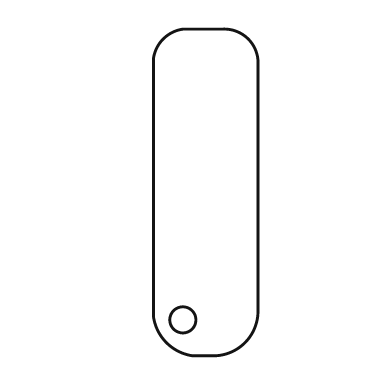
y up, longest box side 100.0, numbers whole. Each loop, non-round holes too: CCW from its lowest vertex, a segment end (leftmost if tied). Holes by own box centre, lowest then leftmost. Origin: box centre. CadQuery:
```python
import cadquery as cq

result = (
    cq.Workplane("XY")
    .moveTo(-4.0, -50.0)
    .lineTo(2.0, -50.0)
    .threePointArc((12.0, -46.0), (16.0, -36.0))
    .lineTo(16.0, 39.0)
    .threePointArc((13.0, 47.0), (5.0, 50.0))
    .lineTo(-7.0, 50.0)
    .threePointArc((-13.0, 47.0), (-16.0, 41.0))
    .lineTo(-16.0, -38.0)
    .threePointArc((-12.0, -46.0), (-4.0, -50.0))
    .close()
    .moveTo(-7.0, -39.0)
    .circle(4.0)
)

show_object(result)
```